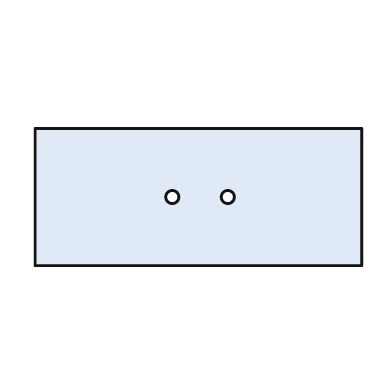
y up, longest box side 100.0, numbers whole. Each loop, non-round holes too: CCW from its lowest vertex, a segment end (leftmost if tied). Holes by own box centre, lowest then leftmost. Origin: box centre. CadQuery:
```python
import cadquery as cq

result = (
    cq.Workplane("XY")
    .moveTo(-50.0, -21.0)
    .lineTo(50.0, -21.0)
    .lineTo(50.0, 21.0)
    .lineTo(-50.0, 21.0)
    .close()
    .moveTo(-8.0, 0.0)
    .circle(2.0)
    .moveTo(9.0, 0.0)
    .circle(2.0)
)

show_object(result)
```